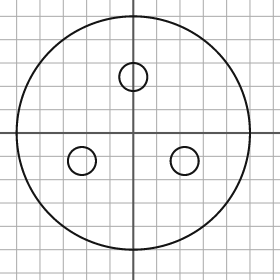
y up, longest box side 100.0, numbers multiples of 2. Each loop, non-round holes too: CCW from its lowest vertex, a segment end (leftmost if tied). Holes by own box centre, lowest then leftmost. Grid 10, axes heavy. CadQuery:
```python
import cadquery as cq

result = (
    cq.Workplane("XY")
    .moveTo(0.0, 0.0)
    .circle(50.0)
    .moveTo(-22.0, -12.0)
    .circle(6.0)
    .moveTo(22.0, -12.0)
    .circle(6.0)
    .moveTo(0.0, 24.0)
    .circle(6.0)
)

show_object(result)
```